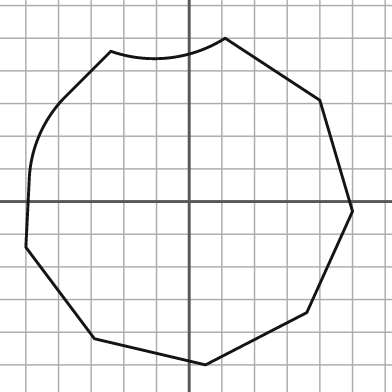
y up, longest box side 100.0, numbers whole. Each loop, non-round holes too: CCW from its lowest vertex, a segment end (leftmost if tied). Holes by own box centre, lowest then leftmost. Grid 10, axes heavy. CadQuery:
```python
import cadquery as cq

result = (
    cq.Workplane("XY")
    .moveTo(5.0, -50.0)
    .lineTo(36.0, -34.0)
    .lineTo(50.0, -3.0)
    .lineTo(40.0, 31.0)
    .lineTo(11.0, 50.0)
    .threePointArc((-6.0, 44.0), (-24.0, 46.0))
    .lineTo(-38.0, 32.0)
    .threePointArc((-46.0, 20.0), (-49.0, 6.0))
    .lineTo(-50.0, -14.0)
    .lineTo(-29.0, -42.0)
    .close()
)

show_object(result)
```